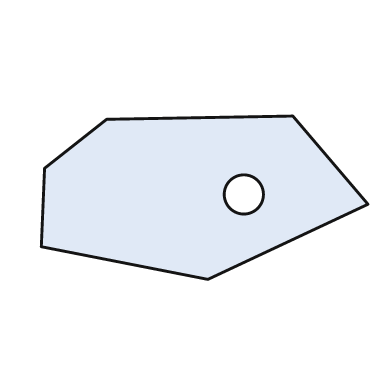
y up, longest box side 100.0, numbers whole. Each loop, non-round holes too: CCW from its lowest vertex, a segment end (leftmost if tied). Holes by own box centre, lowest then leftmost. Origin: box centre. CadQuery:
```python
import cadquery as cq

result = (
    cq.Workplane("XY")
    .moveTo(1.0, -25.0)
    .lineTo(50.0, -2.0)
    .lineTo(27.0, 25.0)
    .lineTo(-30.0, 24.0)
    .lineTo(-49.0, 9.0)
    .lineTo(-50.0, -15.0)
    .close()
    .moveTo(12.0, 1.0)
    .circle(6.0)
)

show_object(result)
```